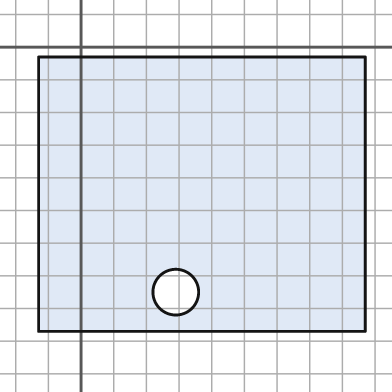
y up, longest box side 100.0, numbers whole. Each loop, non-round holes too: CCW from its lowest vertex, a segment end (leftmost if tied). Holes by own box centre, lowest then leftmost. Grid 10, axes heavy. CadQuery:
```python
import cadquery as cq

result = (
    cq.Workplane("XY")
    .moveTo(-13.0, -87.0)
    .lineTo(87.0, -87.0)
    .lineTo(87.0, -3.0)
    .lineTo(-13.0, -3.0)
    .close()
    .moveTo(29.0, -75.0)
    .circle(7.0)
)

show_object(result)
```